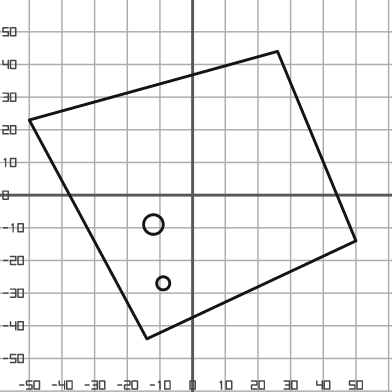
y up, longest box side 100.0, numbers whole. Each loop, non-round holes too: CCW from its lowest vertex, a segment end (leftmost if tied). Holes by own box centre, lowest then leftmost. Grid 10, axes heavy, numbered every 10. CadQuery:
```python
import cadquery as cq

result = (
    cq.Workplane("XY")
    .moveTo(-14.0, -44.0)
    .lineTo(50.0, -14.0)
    .lineTo(26.0, 44.0)
    .lineTo(-50.0, 23.0)
    .close()
    .moveTo(-9.0, -27.0)
    .circle(2.0)
    .moveTo(-12.0, -9.0)
    .circle(3.0)
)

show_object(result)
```